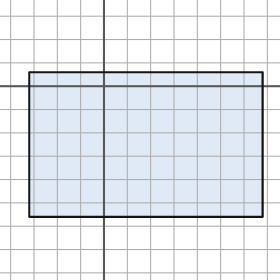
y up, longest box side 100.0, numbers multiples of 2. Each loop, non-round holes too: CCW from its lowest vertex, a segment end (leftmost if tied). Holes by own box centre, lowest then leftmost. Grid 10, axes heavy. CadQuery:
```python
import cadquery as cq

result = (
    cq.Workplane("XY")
    .moveTo(-32.0, -56.0)
    .lineTo(68.0, -56.0)
    .lineTo(68.0, 6.0)
    .lineTo(-32.0, 6.0)
    .close()
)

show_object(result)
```